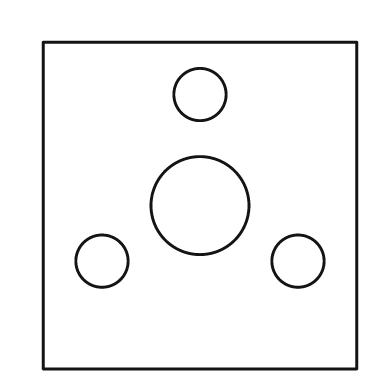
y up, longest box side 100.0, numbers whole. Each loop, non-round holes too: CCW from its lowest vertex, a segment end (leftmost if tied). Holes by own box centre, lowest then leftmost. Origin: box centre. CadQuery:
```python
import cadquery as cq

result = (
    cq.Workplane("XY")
    .moveTo(-48.0, -50.0)
    .lineTo(48.0, -50.0)
    .lineTo(48.0, 50.0)
    .lineTo(-48.0, 50.0)
    .close()
    .moveTo(-30.0, -17.0)
    .circle(8.0)
    .moveTo(30.0, -17.0)
    .circle(8.0)
    .moveTo(0.0, 0.0)
    .circle(15.0)
    .moveTo(0.0, 34.0)
    .circle(8.0)
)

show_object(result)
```